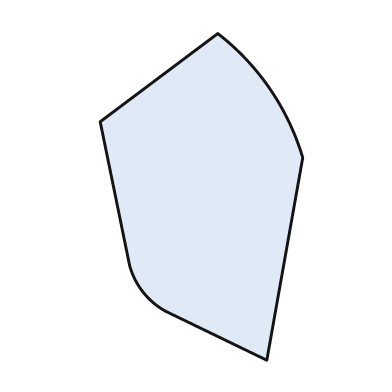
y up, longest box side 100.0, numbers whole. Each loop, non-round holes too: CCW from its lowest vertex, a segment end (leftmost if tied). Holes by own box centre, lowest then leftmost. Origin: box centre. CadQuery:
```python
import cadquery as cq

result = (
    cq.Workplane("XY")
    .moveTo(20.0, -50.0)
    .lineTo(31.0, 12.0)
    .threePointArc((21.0, 33.0), (5.0, 50.0))
    .lineTo(-31.0, 23.0)
    .lineTo(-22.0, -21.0)
    .threePointArc((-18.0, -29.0), (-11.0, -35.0))
    .close()
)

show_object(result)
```